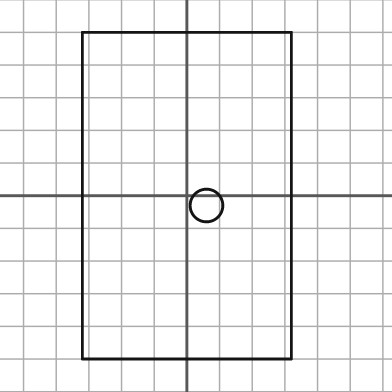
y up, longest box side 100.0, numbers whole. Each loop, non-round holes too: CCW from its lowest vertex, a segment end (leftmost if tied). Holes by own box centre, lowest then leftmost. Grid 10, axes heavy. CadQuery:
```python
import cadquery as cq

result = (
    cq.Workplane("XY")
    .moveTo(-32.0, -50.0)
    .lineTo(32.0, -50.0)
    .lineTo(32.0, 50.0)
    .lineTo(-32.0, 50.0)
    .close()
    .moveTo(6.0, -3.0)
    .circle(5.0)
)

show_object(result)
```